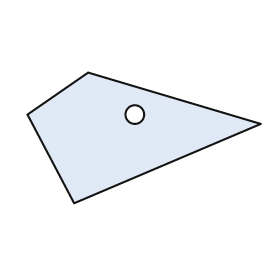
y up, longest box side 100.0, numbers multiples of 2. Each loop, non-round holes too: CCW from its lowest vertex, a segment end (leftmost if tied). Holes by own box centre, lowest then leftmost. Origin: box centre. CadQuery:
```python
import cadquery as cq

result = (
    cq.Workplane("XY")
    .moveTo(-30.0, -28.0)
    .lineTo(50.0, 6.0)
    .lineTo(-24.0, 28.0)
    .lineTo(-50.0, 10.0)
    .close()
    .moveTo(-4.0, 10.0)
    .circle(4.0)
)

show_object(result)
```